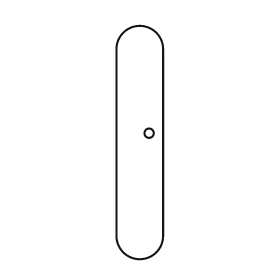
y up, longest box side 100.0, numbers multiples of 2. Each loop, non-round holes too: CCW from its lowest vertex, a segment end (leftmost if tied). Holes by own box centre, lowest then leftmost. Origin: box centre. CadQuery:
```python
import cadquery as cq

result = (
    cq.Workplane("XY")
    .moveTo(-10.0, -40.0)
    .threePointArc((0.0, -50.0), (10.0, -40.0))
    .lineTo(10.0, 40.0)
    .threePointArc((0.0, 50.0), (-10.0, 40.0))
    .close()
    .moveTo(4.0, 4.0)
    .circle(2.0)
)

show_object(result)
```